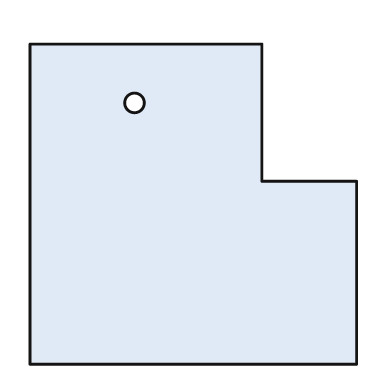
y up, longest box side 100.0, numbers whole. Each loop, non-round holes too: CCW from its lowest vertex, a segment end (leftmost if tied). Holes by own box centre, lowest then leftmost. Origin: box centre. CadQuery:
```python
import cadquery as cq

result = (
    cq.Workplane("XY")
    .moveTo(-50.0, -49.0)
    .lineTo(50.0, -49.0)
    .lineTo(50.0, 7.0)
    .lineTo(21.0, 7.0)
    .lineTo(21.0, 49.0)
    .lineTo(-50.0, 49.0)
    .close()
    .moveTo(-18.0, 31.0)
    .circle(3.0)
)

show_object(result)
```